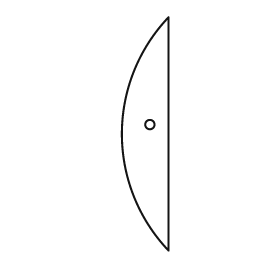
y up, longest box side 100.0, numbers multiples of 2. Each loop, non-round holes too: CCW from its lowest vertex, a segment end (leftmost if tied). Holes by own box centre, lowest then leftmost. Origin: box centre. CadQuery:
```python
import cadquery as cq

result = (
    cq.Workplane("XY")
    .moveTo(10.0, -50.0)
    .lineTo(10.0, 50.0)
    .threePointArc((-10.0, 0.0), (10.0, -50.0))
    .close()
    .moveTo(2.0, 4.0)
    .circle(2.0)
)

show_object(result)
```